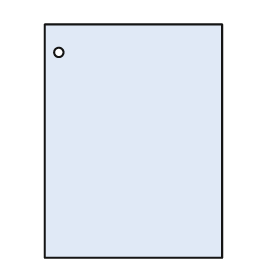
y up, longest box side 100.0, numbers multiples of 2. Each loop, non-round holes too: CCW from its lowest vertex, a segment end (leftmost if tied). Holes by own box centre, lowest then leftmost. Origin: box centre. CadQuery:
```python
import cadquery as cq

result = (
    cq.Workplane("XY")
    .moveTo(-38.0, -50.0)
    .lineTo(38.0, -50.0)
    .lineTo(38.0, 50.0)
    .lineTo(-38.0, 50.0)
    .close()
    .moveTo(-32.0, 38.0)
    .circle(2.0)
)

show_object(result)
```